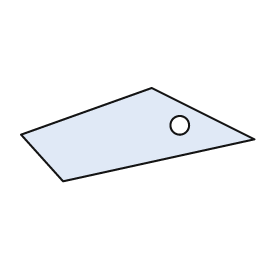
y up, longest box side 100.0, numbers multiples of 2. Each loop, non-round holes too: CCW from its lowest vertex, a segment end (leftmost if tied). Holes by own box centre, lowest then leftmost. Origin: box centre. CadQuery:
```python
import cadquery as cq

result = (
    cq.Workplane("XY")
    .moveTo(-32.0, -20.0)
    .lineTo(50.0, -2.0)
    .lineTo(6.0, 20.0)
    .lineTo(-50.0, 0.0)
    .close()
    .moveTo(18.0, 4.0)
    .circle(4.0)
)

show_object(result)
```